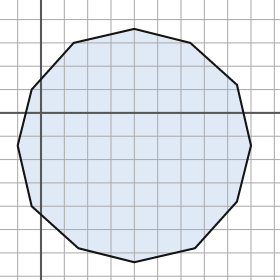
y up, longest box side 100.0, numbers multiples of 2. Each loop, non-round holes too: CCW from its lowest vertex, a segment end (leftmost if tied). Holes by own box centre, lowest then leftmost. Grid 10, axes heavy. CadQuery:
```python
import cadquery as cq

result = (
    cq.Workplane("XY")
    .moveTo(40.0, -64.0)
    .lineTo(66.0, -58.0)
    .lineTo(84.0, -38.0)
    .lineTo(90.0, -14.0)
    .lineTo(84.0, 12.0)
    .lineTo(64.0, 30.0)
    .lineTo(40.0, 36.0)
    .lineTo(14.0, 30.0)
    .lineTo(-4.0, 10.0)
    .lineTo(-10.0, -14.0)
    .lineTo(-4.0, -40.0)
    .lineTo(16.0, -58.0)
    .close()
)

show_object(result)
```